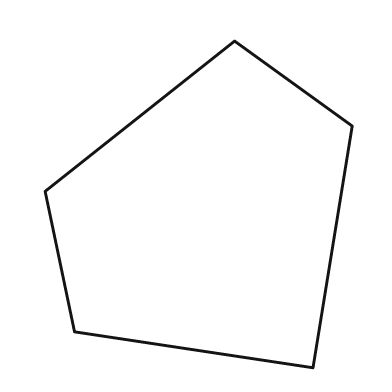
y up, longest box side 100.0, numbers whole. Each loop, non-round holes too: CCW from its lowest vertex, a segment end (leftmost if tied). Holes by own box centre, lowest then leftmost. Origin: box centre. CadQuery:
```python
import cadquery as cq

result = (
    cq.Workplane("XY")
    .moveTo(35.0, -50.0)
    .lineTo(47.0, 24.0)
    .lineTo(11.0, 50.0)
    .lineTo(-47.0, 4.0)
    .lineTo(-38.0, -39.0)
    .close()
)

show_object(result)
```